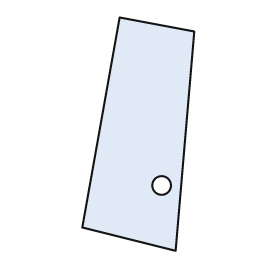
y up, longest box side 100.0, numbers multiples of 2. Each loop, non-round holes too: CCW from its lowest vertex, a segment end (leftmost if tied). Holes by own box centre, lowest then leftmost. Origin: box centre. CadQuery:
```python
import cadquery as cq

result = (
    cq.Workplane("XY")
    .moveTo(16.0, -50.0)
    .lineTo(24.0, 44.0)
    .lineTo(-8.0, 50.0)
    .lineTo(-24.0, -40.0)
    .close()
    .moveTo(10.0, -22.0)
    .circle(4.0)
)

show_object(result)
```